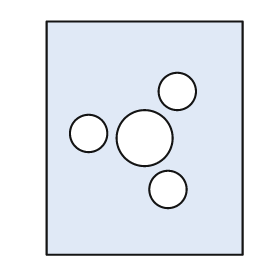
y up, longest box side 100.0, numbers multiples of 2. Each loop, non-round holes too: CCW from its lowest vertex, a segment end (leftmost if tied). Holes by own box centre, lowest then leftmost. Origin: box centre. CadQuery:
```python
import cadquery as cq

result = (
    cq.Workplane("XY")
    .moveTo(-42.0, -50.0)
    .lineTo(42.0, -50.0)
    .lineTo(42.0, 50.0)
    .lineTo(-42.0, 50.0)
    .close()
    .moveTo(10.0, -22.0)
    .circle(8.0)
    .moveTo(0.0, 0.0)
    .circle(12.0)
    .moveTo(-24.0, 2.0)
    .circle(8.0)
    .moveTo(14.0, 20.0)
    .circle(8.0)
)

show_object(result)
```